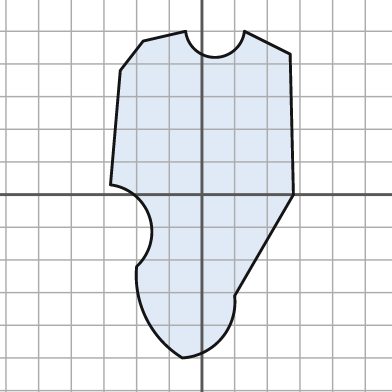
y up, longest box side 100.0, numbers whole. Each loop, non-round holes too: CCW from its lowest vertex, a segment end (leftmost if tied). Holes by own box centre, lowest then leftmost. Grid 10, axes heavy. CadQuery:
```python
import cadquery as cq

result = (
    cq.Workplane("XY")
    .moveTo(-6.0, -50.0)
    .threePointArc((6.0, -44.0), (10.0, -31.0))
    .lineTo(28.0, 0.0)
    .lineTo(27.0, 43.0)
    .lineTo(13.0, 50.0)
    .threePointArc((4.0, 42.0), (-5.0, 50.0))
    .lineTo(-18.0, 47.0)
    .lineTo(-25.0, 38.0)
    .lineTo(-28.0, 3.0)
    .threePointArc((-16.0, -7.0), (-20.0, -22.0))
    .threePointArc((-17.0, -38.0), (-6.0, -50.0))
    .close()
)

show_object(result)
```